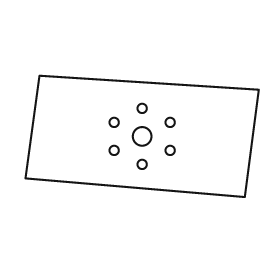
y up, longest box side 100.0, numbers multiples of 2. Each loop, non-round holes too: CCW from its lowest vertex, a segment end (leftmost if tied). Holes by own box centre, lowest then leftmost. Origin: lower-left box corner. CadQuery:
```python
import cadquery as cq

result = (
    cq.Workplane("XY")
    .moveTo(94.0, 0.0)
    .lineTo(100.0, 46.0)
    .lineTo(6.0, 52.0)
    .lineTo(0.0, 8.0)
    .close()
    .moveTo(50.0, 14.0)
    .circle(2.0)
    .moveTo(38.0, 20.0)
    .circle(2.0)
    .moveTo(62.0, 20.0)
    .circle(2.0)
    .moveTo(50.0, 26.0)
    .circle(4.0)
    .moveTo(38.0, 32.0)
    .circle(2.0)
    .moveTo(62.0, 32.0)
    .circle(2.0)
    .moveTo(50.0, 38.0)
    .circle(2.0)
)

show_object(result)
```